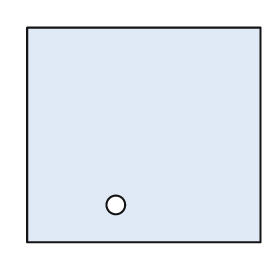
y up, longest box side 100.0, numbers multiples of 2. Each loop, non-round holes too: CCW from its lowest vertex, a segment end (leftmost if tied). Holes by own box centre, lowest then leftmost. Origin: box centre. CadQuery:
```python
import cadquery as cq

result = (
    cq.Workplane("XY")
    .moveTo(-50.0, -46.0)
    .lineTo(50.0, -46.0)
    .lineTo(50.0, 46.0)
    .lineTo(-50.0, 46.0)
    .close()
    .moveTo(-12.0, -30.0)
    .circle(4.0)
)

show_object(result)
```